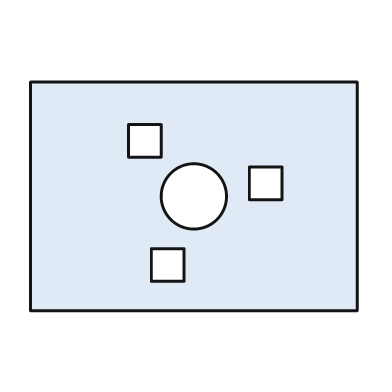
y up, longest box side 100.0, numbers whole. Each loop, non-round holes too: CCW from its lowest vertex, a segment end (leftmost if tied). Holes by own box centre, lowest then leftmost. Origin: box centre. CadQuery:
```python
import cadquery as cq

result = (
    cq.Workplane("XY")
    .moveTo(-50.0, -35.0)
    .lineTo(50.0, -35.0)
    .lineTo(50.0, 35.0)
    .lineTo(-50.0, 35.0)
    .close()
    .moveTo(-13.0, -26.0)
    .lineTo(-3.0, -26.0)
    .lineTo(-3.0, -16.0)
    .lineTo(-13.0, -16.0)
    .close()
    .moveTo(0.0, 0.0)
    .circle(10.0)
    .moveTo(17.0, -1.0)
    .lineTo(27.0, -1.0)
    .lineTo(27.0, 9.0)
    .lineTo(17.0, 9.0)
    .close()
    .moveTo(-20.0, 12.0)
    .lineTo(-10.0, 12.0)
    .lineTo(-10.0, 22.0)
    .lineTo(-20.0, 22.0)
    .close()
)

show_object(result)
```